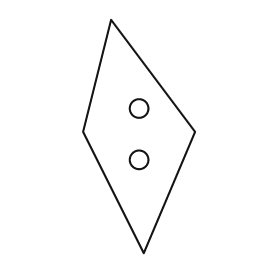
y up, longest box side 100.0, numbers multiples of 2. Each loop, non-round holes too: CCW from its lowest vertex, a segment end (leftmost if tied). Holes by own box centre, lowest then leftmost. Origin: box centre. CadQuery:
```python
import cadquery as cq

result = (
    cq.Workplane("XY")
    .moveTo(2.0, -50.0)
    .lineTo(24.0, 2.0)
    .lineTo(-12.0, 50.0)
    .lineTo(-24.0, 2.0)
    .close()
    .moveTo(0.0, -10.0)
    .circle(4.0)
    .moveTo(0.0, 12.0)
    .circle(4.0)
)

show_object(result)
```